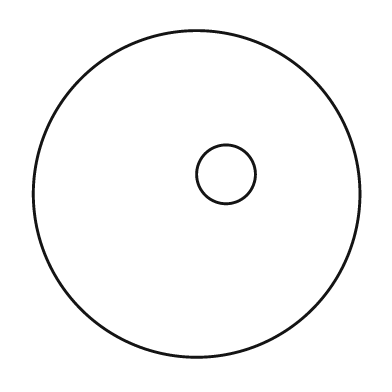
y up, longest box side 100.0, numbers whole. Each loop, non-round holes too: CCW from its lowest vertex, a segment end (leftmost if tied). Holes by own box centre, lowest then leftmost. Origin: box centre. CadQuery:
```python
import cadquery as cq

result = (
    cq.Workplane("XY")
    .moveTo(0.0, 0.0)
    .circle(50.0)
    .moveTo(9.0, 6.0)
    .circle(9.0)
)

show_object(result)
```